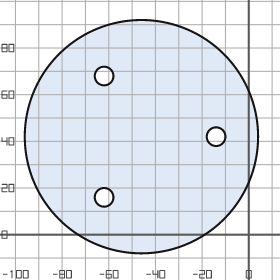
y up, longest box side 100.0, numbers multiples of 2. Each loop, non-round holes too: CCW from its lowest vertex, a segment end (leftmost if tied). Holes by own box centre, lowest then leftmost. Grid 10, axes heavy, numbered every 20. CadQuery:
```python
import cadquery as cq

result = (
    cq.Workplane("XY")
    .moveTo(-46.0, 42.0)
    .circle(50.0)
    .moveTo(-62.0, 16.0)
    .circle(4.0)
    .moveTo(-14.0, 42.0)
    .circle(4.0)
    .moveTo(-62.0, 68.0)
    .circle(4.0)
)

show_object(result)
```